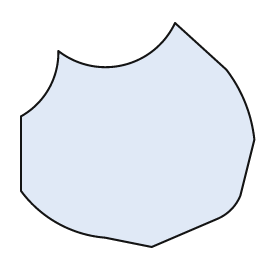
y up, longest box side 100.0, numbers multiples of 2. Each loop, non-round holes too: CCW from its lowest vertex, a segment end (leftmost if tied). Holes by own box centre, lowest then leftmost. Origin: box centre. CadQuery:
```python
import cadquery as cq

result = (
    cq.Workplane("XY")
    .moveTo(6.0, -48.0)
    .lineTo(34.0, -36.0)
    .threePointArc((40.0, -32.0), (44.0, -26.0))
    .lineTo(50.0, -2.0)
    .threePointArc((46.0, 14.0), (38.0, 28.0))
    .lineTo(16.0, 48.0)
    .threePointArc((-6.0, 30.0), (-34.0, 36.0))
    .threePointArc((-38.0, 20.0), (-50.0, 8.0))
    .lineTo(-50.0, -24.0)
    .threePointArc((-34.0, -38.0), (-14.0, -44.0))
    .close()
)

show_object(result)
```